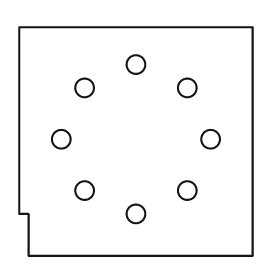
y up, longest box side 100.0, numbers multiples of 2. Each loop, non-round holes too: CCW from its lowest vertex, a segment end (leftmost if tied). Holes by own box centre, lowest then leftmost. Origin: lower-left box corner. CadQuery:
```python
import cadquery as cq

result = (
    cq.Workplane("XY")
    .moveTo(4.0, 0.0)
    .lineTo(100.0, 0.0)
    .lineTo(100.0, 98.0)
    .lineTo(0.0, 98.0)
    .lineTo(0.0, 18.0)
    .lineTo(4.0, 18.0)
    .close()
    .moveTo(50.0, 18.0)
    .circle(4.0)
    .moveTo(28.0, 28.0)
    .circle(4.0)
    .moveTo(72.0, 28.0)
    .circle(4.0)
    .moveTo(18.0, 50.0)
    .circle(4.0)
    .moveTo(82.0, 50.0)
    .circle(4.0)
    .moveTo(28.0, 72.0)
    .circle(4.0)
    .moveTo(72.0, 72.0)
    .circle(4.0)
    .moveTo(50.0, 82.0)
    .circle(4.0)
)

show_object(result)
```